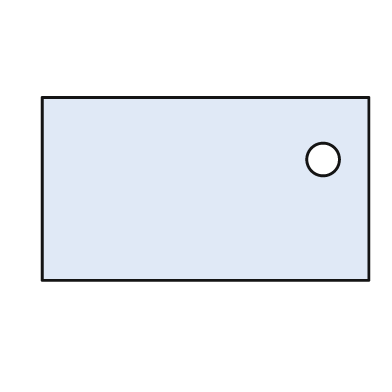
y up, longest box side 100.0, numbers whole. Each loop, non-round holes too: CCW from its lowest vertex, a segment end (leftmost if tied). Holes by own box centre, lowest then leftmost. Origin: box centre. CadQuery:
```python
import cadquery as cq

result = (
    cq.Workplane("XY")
    .moveTo(-50.0, -28.0)
    .lineTo(50.0, -28.0)
    .lineTo(50.0, 28.0)
    .lineTo(-50.0, 28.0)
    .close()
    .moveTo(36.0, 9.0)
    .circle(5.0)
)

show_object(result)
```